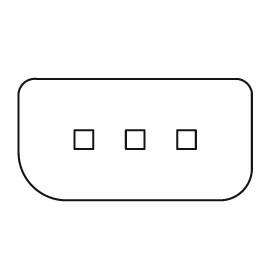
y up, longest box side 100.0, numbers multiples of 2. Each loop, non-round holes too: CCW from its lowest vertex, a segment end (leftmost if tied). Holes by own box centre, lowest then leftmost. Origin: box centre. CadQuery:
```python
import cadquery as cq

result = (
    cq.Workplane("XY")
    .moveTo(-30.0, -26.0)
    .lineTo(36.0, -26.0)
    .threePointArc((46.0, -22.0), (50.0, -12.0))
    .lineTo(50.0, 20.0)
    .threePointArc((48.0, 24.0), (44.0, 26.0))
    .lineTo(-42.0, 26.0)
    .threePointArc((-48.0, 24.0), (-50.0, 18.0))
    .lineTo(-50.0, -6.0)
    .threePointArc((-44.0, -20.0), (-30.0, -26.0))
    .close()
    .moveTo(-26.0, -4.0)
    .lineTo(-18.0, -4.0)
    .lineTo(-18.0, 4.0)
    .lineTo(-26.0, 4.0)
    .close()
    .moveTo(-4.0, -4.0)
    .lineTo(4.0, -4.0)
    .lineTo(4.0, 4.0)
    .lineTo(-4.0, 4.0)
    .close()
    .moveTo(18.0, -4.0)
    .lineTo(26.0, -4.0)
    .lineTo(26.0, 4.0)
    .lineTo(18.0, 4.0)
    .close()
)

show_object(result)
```